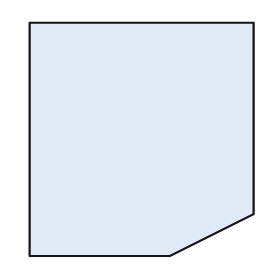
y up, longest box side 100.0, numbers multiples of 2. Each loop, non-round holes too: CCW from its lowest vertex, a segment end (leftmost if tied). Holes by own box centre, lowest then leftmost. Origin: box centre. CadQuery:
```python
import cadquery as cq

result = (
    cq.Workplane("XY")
    .moveTo(-48.0, -50.0)
    .lineTo(12.0, -50.0)
    .lineTo(48.0, -32.0)
    .lineTo(48.0, 50.0)
    .lineTo(-48.0, 50.0)
    .close()
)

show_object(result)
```